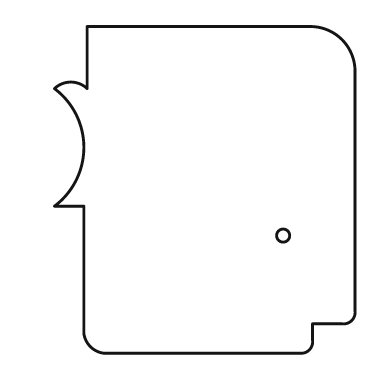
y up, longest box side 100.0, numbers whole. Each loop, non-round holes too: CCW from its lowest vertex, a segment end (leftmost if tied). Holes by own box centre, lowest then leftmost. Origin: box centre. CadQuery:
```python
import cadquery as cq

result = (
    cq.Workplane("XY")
    .moveTo(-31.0, -50.0)
    .lineTo(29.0, -50.0)
    .threePointArc((32.0, -49.0), (33.0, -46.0))
    .lineTo(33.0, -41.0)
    .lineTo(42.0, -41.0)
    .threePointArc((45.0, -40.0), (46.0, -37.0))
    .lineTo(46.0, 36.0)
    .threePointArc((42.0, 46.0), (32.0, 50.0))
    .lineTo(-36.0, 50.0)
    .lineTo(-36.0, 31.0)
    .threePointArc((-41.0, 33.0), (-46.0, 31.0))
    .threePointArc((-37.0, 13.0), (-46.0, -5.0))
    .lineTo(-37.0, -5.0)
    .lineTo(-37.0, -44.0)
    .threePointArc((-35.0, -48.0), (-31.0, -50.0))
    .close()
    .moveTo(24.0, -14.0)
    .circle(2.0)
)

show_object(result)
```